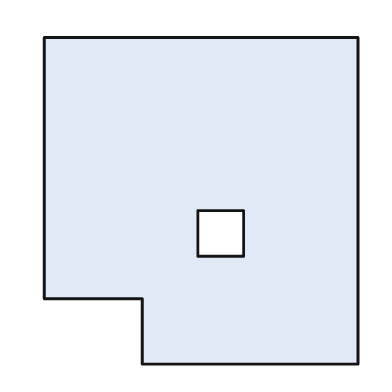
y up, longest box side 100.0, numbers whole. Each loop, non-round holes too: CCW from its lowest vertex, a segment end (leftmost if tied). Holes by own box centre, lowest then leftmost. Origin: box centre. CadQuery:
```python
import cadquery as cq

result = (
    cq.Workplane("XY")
    .moveTo(-18.0, -50.0)
    .lineTo(48.0, -50.0)
    .lineTo(48.0, 50.0)
    .lineTo(-48.0, 50.0)
    .lineTo(-48.0, -30.0)
    .lineTo(-18.0, -30.0)
    .close()
    .moveTo(-1.0, -17.0)
    .lineTo(13.0, -17.0)
    .lineTo(13.0, -3.0)
    .lineTo(-1.0, -3.0)
    .close()
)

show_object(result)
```